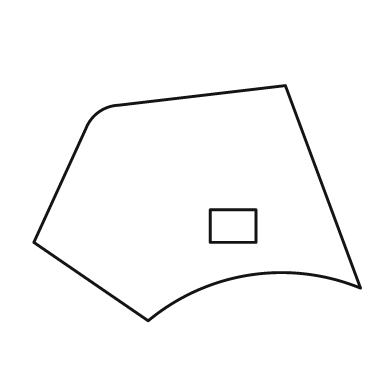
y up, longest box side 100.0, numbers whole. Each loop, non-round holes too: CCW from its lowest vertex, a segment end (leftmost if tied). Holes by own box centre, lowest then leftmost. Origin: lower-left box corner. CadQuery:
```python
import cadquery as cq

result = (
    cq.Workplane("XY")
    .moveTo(35.0, 0.0)
    .threePointArc((66.0, 14.0), (100.0, 10.0))
    .lineTo(77.0, 72.0)
    .lineTo(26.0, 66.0)
    .threePointArc((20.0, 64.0), (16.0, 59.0))
    .lineTo(0.0, 24.0)
    .close()
    .moveTo(54.0, 24.0)
    .lineTo(68.0, 24.0)
    .lineTo(68.0, 34.0)
    .lineTo(54.0, 34.0)
    .close()
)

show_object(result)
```